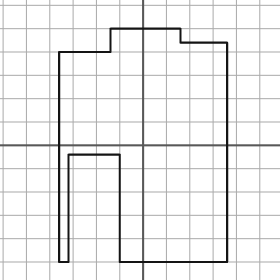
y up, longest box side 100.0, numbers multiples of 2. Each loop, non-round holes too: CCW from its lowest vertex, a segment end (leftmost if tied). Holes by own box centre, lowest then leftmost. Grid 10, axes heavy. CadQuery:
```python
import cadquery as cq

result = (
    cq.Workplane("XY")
    .moveTo(-36.0, -50.0)
    .lineTo(-32.0, -50.0)
    .lineTo(-32.0, -4.0)
    .lineTo(-10.0, -4.0)
    .lineTo(-10.0, -50.0)
    .lineTo(36.0, -50.0)
    .lineTo(36.0, 44.0)
    .lineTo(16.0, 44.0)
    .lineTo(16.0, 50.0)
    .lineTo(-14.0, 50.0)
    .lineTo(-14.0, 40.0)
    .lineTo(-36.0, 40.0)
    .close()
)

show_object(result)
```